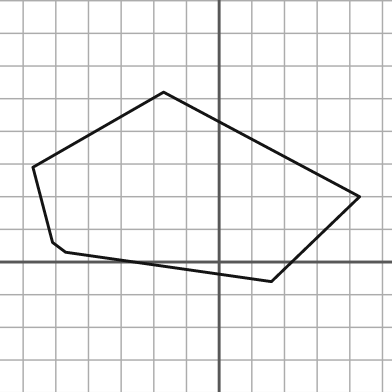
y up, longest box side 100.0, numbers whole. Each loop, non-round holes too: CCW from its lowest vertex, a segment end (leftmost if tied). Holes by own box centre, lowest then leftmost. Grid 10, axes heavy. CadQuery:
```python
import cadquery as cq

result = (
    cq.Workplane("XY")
    .moveTo(16.0, -6.0)
    .lineTo(43.0, 20.0)
    .lineTo(-17.0, 52.0)
    .lineTo(-57.0, 29.0)
    .lineTo(-51.0, 6.0)
    .lineTo(-47.0, 3.0)
    .close()
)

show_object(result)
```